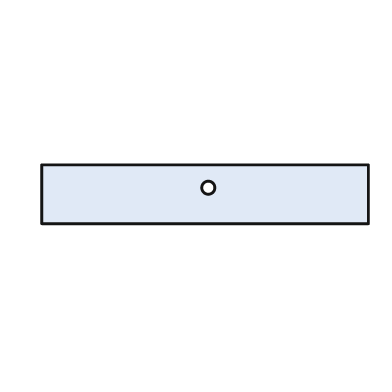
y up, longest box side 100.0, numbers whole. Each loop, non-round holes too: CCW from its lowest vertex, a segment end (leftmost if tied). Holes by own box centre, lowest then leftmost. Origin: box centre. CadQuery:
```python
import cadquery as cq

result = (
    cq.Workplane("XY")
    .moveTo(-50.0, -9.0)
    .lineTo(50.0, -9.0)
    .lineTo(50.0, 9.0)
    .lineTo(-50.0, 9.0)
    .close()
    .moveTo(1.0, 2.0)
    .circle(2.0)
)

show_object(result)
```